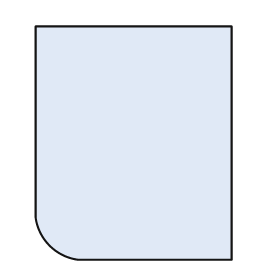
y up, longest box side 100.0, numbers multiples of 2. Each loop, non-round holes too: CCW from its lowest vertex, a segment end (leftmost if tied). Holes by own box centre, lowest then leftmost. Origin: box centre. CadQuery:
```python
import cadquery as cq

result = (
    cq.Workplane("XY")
    .moveTo(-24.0, -50.0)
    .lineTo(42.0, -50.0)
    .lineTo(42.0, 50.0)
    .lineTo(-42.0, 50.0)
    .lineTo(-42.0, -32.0)
    .threePointArc((-36.0, -44.0), (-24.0, -50.0))
    .close()
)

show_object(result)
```